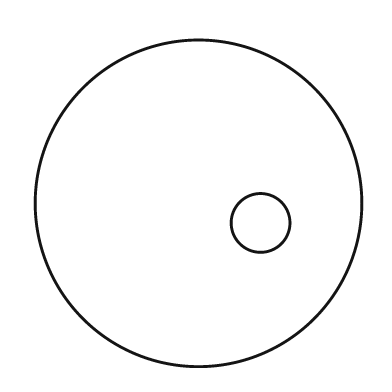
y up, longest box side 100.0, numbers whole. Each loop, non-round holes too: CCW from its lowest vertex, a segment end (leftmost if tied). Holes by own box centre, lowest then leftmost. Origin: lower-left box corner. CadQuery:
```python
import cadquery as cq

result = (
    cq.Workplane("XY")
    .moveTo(50.0, 50.0)
    .circle(50.0)
    .moveTo(69.0, 44.0)
    .circle(9.0)
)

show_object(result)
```